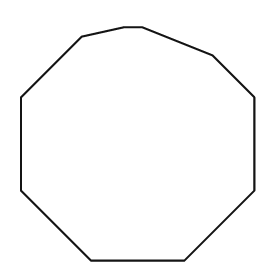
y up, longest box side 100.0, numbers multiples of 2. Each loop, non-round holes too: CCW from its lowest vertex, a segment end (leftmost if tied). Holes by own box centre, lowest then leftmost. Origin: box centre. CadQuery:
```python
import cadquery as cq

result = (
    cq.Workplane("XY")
    .moveTo(-20.0, -50.0)
    .lineTo(20.0, -50.0)
    .lineTo(50.0, -20.0)
    .lineTo(50.0, 20.0)
    .lineTo(32.0, 38.0)
    .lineTo(2.0, 50.0)
    .lineTo(-6.0, 50.0)
    .lineTo(-24.0, 46.0)
    .lineTo(-50.0, 20.0)
    .lineTo(-50.0, -20.0)
    .close()
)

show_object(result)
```